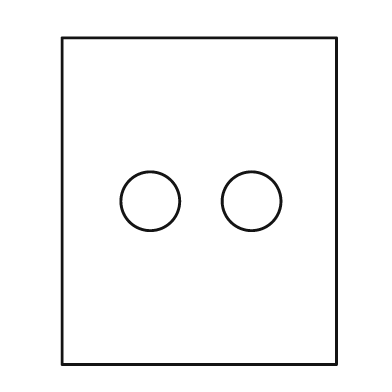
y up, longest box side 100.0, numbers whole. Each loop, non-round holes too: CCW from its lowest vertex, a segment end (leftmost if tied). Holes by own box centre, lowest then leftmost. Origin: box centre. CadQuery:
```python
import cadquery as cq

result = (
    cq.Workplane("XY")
    .moveTo(-42.0, -50.0)
    .lineTo(42.0, -50.0)
    .lineTo(42.0, 50.0)
    .lineTo(-42.0, 50.0)
    .close()
    .moveTo(-15.0, 0.0)
    .circle(9.0)
    .moveTo(16.0, 0.0)
    .circle(9.0)
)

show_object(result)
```